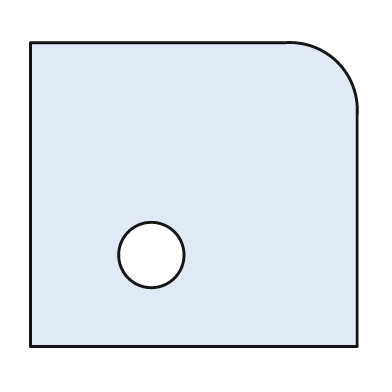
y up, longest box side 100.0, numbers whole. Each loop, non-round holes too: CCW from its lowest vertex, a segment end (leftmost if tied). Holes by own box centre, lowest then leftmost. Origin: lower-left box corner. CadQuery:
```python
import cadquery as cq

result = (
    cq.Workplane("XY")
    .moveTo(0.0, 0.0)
    .lineTo(100.0, 0.0)
    .lineTo(100.0, 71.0)
    .threePointArc((94.0, 87.0), (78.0, 93.0))
    .lineTo(0.0, 93.0)
    .close()
    .moveTo(37.0, 28.0)
    .circle(10.0)
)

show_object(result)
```